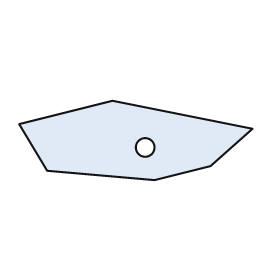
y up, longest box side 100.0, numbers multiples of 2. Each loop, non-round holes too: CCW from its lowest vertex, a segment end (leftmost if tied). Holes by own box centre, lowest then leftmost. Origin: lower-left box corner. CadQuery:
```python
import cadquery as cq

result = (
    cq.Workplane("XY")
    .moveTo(58.0, 0.0)
    .lineTo(82.0, 6.0)
    .lineTo(100.0, 22.0)
    .lineTo(40.0, 34.0)
    .lineTo(0.0, 24.0)
    .lineTo(12.0, 4.0)
    .close()
    .moveTo(54.0, 14.0)
    .circle(4.0)
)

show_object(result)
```